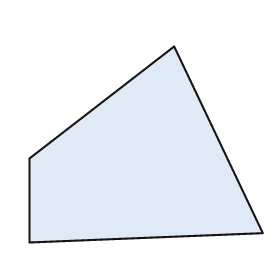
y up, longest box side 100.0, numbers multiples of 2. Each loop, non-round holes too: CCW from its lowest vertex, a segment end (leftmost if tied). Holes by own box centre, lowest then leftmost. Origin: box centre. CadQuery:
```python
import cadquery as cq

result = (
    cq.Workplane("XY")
    .moveTo(-50.0, -42.0)
    .lineTo(50.0, -38.0)
    .lineTo(12.0, 42.0)
    .lineTo(-50.0, -6.0)
    .close()
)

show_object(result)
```